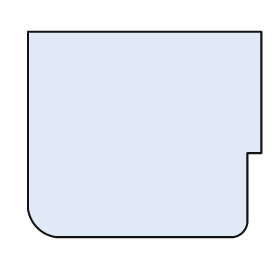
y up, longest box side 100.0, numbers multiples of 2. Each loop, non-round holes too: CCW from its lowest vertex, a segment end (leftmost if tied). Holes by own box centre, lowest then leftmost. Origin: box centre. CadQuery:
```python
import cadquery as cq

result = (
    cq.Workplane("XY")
    .moveTo(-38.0, -44.0)
    .lineTo(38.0, -44.0)
    .threePointArc((42.0, -42.0), (44.0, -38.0))
    .lineTo(44.0, -8.0)
    .lineTo(50.0, -8.0)
    .lineTo(50.0, 44.0)
    .lineTo(-50.0, 44.0)
    .lineTo(-50.0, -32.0)
    .threePointArc((-46.0, -40.0), (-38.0, -44.0))
    .close()
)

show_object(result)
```